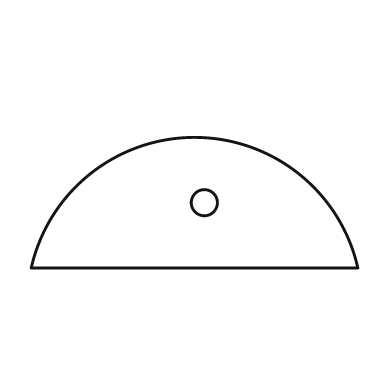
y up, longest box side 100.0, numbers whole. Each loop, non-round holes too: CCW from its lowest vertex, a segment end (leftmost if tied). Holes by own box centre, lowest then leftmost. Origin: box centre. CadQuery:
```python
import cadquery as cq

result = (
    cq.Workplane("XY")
    .moveTo(-50.0, -20.0)
    .lineTo(50.0, -20.0)
    .threePointArc((0.0, 20.0), (-50.0, -20.0))
    .close()
    .moveTo(3.0, 0.0)
    .circle(4.0)
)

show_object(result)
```